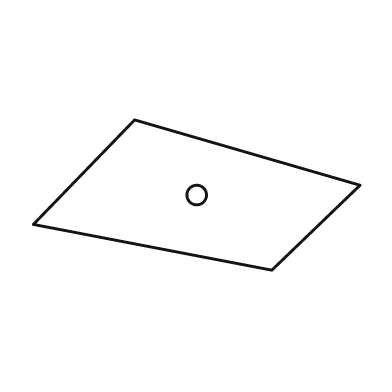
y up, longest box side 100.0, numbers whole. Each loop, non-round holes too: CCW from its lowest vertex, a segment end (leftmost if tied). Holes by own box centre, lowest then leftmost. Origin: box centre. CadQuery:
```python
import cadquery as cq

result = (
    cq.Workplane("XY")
    .moveTo(23.0, -23.0)
    .lineTo(50.0, 3.0)
    .lineTo(-19.0, 23.0)
    .lineTo(-50.0, -9.0)
    .close()
    .moveTo(0.0, 0.0)
    .circle(3.0)
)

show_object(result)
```